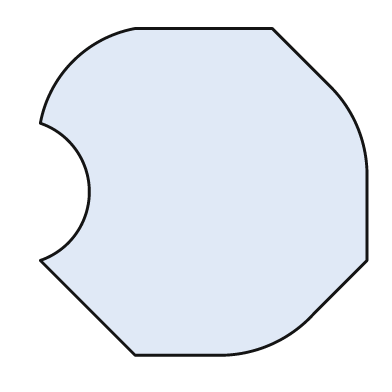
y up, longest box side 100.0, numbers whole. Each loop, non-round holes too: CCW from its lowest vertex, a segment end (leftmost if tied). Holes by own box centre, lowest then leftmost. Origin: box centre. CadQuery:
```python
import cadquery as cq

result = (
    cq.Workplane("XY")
    .moveTo(-21.0, -50.0)
    .lineTo(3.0, -50.0)
    .threePointArc((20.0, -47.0), (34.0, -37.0))
    .lineTo(50.0, -21.0)
    .lineTo(50.0, 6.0)
    .threePointArc((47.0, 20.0), (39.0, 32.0))
    .lineTo(21.0, 50.0)
    .lineTo(-21.0, 50.0)
    .threePointArc((-40.0, 40.0), (-50.0, 21.0))
    .threePointArc((-35.0, 0.0), (-50.0, -21.0))
    .close()
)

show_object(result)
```